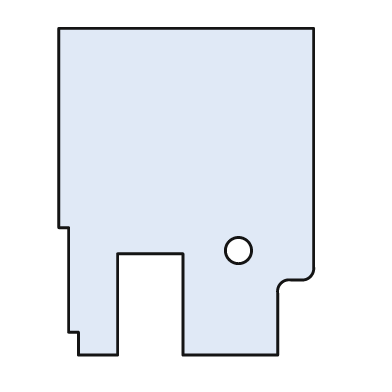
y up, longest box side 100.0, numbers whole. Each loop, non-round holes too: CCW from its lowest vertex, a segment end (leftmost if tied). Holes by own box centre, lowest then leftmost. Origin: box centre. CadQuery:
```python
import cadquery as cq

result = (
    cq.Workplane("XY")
    .moveTo(-33.0, -50.0)
    .lineTo(-21.0, -50.0)
    .lineTo(-21.0, -19.0)
    .lineTo(-1.0, -19.0)
    .lineTo(-1.0, -50.0)
    .lineTo(28.0, -50.0)
    .lineTo(28.0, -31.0)
    .threePointArc((29.0, -28.0), (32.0, -27.0))
    .lineTo(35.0, -27.0)
    .threePointArc((38.0, -26.0), (39.0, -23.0))
    .lineTo(39.0, 50.0)
    .lineTo(-39.0, 50.0)
    .lineTo(-39.0, -11.0)
    .lineTo(-36.0, -11.0)
    .lineTo(-36.0, -43.0)
    .lineTo(-33.0, -43.0)
    .close()
    .moveTo(16.0, -18.0)
    .circle(4.0)
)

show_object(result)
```